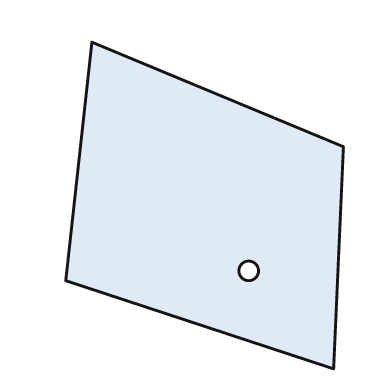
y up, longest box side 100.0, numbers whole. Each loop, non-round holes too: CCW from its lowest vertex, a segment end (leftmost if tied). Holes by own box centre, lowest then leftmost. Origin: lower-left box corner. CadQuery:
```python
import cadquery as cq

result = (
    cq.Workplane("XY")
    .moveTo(82.0, 0.0)
    .lineTo(85.0, 68.0)
    .lineTo(8.0, 100.0)
    .lineTo(0.0, 27.0)
    .close()
    .moveTo(56.0, 30.0)
    .circle(3.0)
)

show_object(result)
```